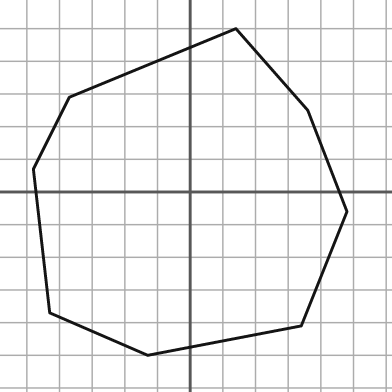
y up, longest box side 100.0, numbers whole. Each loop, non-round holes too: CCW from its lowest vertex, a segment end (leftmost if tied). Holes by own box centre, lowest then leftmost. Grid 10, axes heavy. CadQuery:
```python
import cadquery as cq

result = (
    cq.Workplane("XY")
    .moveTo(-13.0, -50.0)
    .lineTo(34.0, -41.0)
    .lineTo(48.0, -6.0)
    .lineTo(36.0, 25.0)
    .lineTo(14.0, 50.0)
    .lineTo(-37.0, 29.0)
    .lineTo(-48.0, 7.0)
    .lineTo(-43.0, -37.0)
    .close()
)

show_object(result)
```